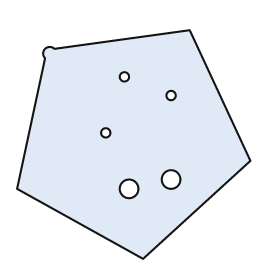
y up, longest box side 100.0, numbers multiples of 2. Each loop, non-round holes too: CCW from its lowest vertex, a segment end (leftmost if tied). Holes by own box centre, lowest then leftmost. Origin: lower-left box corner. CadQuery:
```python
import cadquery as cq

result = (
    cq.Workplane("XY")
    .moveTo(54.0, 0.0)
    .lineTo(100.0, 42.0)
    .lineTo(74.0, 98.0)
    .lineTo(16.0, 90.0)
    .threePointArc((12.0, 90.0), (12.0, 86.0))
    .lineTo(0.0, 30.0)
    .close()
    .moveTo(48.0, 30.0)
    .circle(4.0)
    .moveTo(66.0, 34.0)
    .circle(4.0)
    .moveTo(38.0, 54.0)
    .circle(2.0)
    .moveTo(66.0, 70.0)
    .circle(2.0)
    .moveTo(46.0, 78.0)
    .circle(2.0)
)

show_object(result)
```